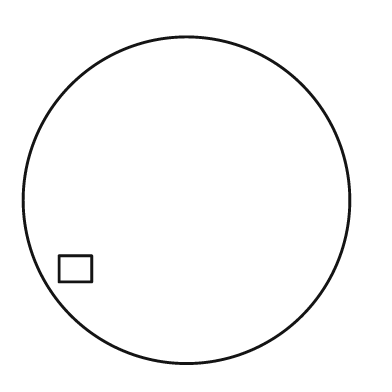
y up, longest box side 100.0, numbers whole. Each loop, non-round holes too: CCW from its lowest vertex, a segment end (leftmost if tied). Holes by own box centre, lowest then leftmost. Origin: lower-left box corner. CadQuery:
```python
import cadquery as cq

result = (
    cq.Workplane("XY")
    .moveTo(50.0, 50.0)
    .circle(50.0)
    .moveTo(11.0, 25.0)
    .lineTo(21.0, 25.0)
    .lineTo(21.0, 33.0)
    .lineTo(11.0, 33.0)
    .close()
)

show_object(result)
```